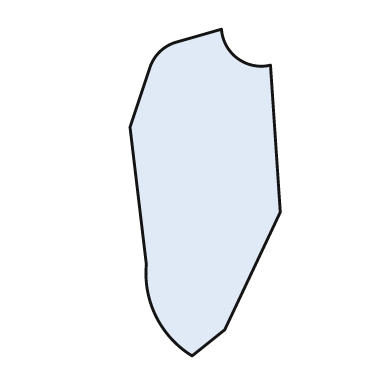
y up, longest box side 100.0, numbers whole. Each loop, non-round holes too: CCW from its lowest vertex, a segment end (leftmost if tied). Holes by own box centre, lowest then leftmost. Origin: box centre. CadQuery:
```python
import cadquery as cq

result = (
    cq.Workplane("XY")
    .moveTo(-4.0, -50.0)
    .lineTo(6.0, -42.0)
    .lineTo(23.0, -6.0)
    .lineTo(20.0, 39.0)
    .threePointArc((10.0, 41.0), (5.0, 50.0))
    .lineTo(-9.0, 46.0)
    .threePointArc((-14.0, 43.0), (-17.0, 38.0))
    .lineTo(-23.0, 20.0)
    .lineTo(-18.0, -22.0)
    .threePointArc((-15.0, -38.0), (-4.0, -50.0))
    .close()
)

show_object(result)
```